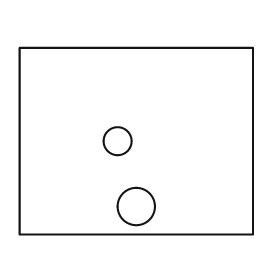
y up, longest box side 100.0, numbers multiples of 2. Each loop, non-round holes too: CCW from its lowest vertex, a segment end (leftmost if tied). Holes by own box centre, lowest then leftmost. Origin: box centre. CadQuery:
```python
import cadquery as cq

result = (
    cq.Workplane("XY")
    .moveTo(-50.0, -40.0)
    .lineTo(50.0, -40.0)
    .lineTo(50.0, 40.0)
    .lineTo(-50.0, 40.0)
    .close()
    .moveTo(0.0, -28.0)
    .circle(8.0)
    .moveTo(-8.0, 0.0)
    .circle(6.0)
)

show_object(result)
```